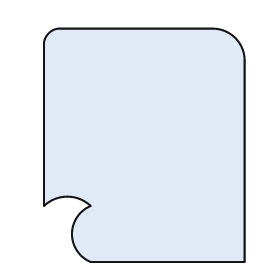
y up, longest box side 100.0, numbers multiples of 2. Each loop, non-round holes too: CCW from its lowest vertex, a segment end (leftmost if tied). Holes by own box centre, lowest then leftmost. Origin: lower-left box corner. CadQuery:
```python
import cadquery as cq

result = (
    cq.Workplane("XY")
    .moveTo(20.0, 0.0)
    .lineTo(86.0, 0.0)
    .lineTo(86.0, 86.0)
    .threePointArc((82.0, 96.0), (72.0, 100.0))
    .lineTo(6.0, 100.0)
    .threePointArc((2.0, 98.0), (0.0, 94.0))
    .lineTo(0.0, 24.0)
    .threePointArc((10.0, 28.0), (20.0, 24.0))
    .threePointArc((12.0, 12.0), (20.0, 0.0))
    .close()
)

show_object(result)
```